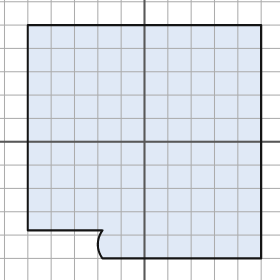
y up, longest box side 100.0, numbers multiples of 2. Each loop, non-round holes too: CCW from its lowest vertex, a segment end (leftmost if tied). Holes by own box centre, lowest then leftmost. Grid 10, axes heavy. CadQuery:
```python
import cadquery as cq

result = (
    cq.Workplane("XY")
    .moveTo(-18.0, -50.0)
    .lineTo(50.0, -50.0)
    .lineTo(50.0, 50.0)
    .lineTo(-50.0, 50.0)
    .lineTo(-50.0, -38.0)
    .lineTo(-18.0, -38.0)
    .threePointArc((-20.0, -44.0), (-18.0, -50.0))
    .close()
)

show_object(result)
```